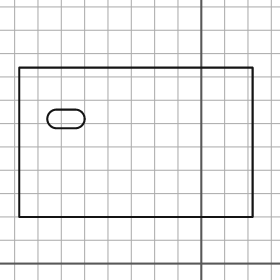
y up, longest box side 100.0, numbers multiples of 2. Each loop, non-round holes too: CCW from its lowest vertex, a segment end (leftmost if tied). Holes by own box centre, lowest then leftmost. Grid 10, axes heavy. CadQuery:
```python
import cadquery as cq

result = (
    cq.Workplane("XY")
    .moveTo(-78.0, 20.0)
    .lineTo(22.0, 20.0)
    .lineTo(22.0, 84.0)
    .lineTo(-78.0, 84.0)
    .close()
    .moveTo(-62.0, 58.0)
    .lineTo(-54.0, 58.0)
    .threePointArc((-50.0, 62.0), (-54.0, 66.0))
    .lineTo(-62.0, 66.0)
    .threePointArc((-66.0, 62.0), (-62.0, 58.0))
    .close()
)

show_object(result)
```